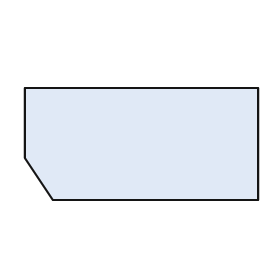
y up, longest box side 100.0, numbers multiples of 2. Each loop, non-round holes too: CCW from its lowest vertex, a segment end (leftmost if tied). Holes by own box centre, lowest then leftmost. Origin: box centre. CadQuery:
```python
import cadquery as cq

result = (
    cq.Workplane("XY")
    .moveTo(-38.0, -24.0)
    .lineTo(50.0, -24.0)
    .lineTo(50.0, 24.0)
    .lineTo(-50.0, 24.0)
    .lineTo(-50.0, -6.0)
    .close()
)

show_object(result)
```